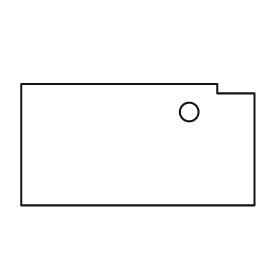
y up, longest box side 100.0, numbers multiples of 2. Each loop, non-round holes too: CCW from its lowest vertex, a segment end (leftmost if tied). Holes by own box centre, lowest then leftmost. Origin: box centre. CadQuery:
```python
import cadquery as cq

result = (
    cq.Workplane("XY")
    .moveTo(-50.0, -26.0)
    .lineTo(50.0, -26.0)
    .lineTo(50.0, 22.0)
    .lineTo(34.0, 22.0)
    .lineTo(34.0, 26.0)
    .lineTo(-50.0, 26.0)
    .close()
    .moveTo(22.0, 14.0)
    .circle(4.0)
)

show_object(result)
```